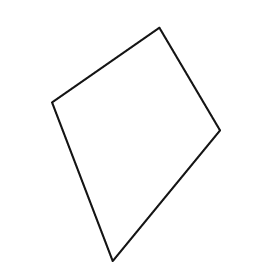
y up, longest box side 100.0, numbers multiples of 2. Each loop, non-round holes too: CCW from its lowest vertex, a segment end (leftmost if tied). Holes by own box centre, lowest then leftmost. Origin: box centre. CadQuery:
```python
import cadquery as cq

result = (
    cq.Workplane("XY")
    .moveTo(-10.0, -50.0)
    .lineTo(36.0, 6.0)
    .lineTo(10.0, 50.0)
    .lineTo(-36.0, 18.0)
    .close()
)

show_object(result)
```